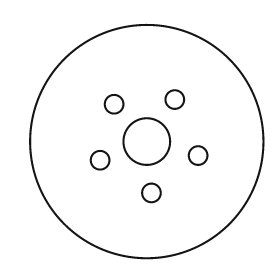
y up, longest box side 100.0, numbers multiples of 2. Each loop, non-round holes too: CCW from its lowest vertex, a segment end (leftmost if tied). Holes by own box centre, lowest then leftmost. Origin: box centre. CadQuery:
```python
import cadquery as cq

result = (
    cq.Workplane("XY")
    .moveTo(0.0, 0.0)
    .circle(50.0)
    .moveTo(2.0, -22.0)
    .circle(4.0)
    .moveTo(-20.0, -8.0)
    .circle(4.0)
    .moveTo(22.0, -6.0)
    .circle(4.0)
    .moveTo(0.0, 0.0)
    .circle(10.0)
    .moveTo(-14.0, 16.0)
    .circle(4.0)
    .moveTo(12.0, 18.0)
    .circle(4.0)
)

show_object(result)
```